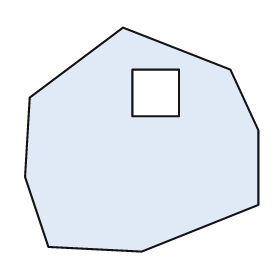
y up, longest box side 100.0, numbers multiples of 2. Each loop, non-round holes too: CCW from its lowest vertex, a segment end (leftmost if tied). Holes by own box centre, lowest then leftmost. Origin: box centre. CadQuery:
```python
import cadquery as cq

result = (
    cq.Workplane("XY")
    .moveTo(0.0, -48.0)
    .lineTo(50.0, -28.0)
    .lineTo(50.0, 4.0)
    .lineTo(38.0, 30.0)
    .lineTo(-8.0, 48.0)
    .lineTo(-48.0, 18.0)
    .lineTo(-50.0, -16.0)
    .lineTo(-40.0, -46.0)
    .close()
    .moveTo(-4.0, 10.0)
    .lineTo(16.0, 10.0)
    .lineTo(16.0, 30.0)
    .lineTo(-4.0, 30.0)
    .close()
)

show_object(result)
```